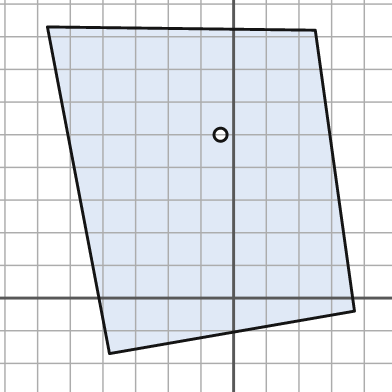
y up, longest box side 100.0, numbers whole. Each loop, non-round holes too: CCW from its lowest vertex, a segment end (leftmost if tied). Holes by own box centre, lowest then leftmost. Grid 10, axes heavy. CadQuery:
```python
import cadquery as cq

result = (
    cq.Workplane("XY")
    .moveTo(-38.0, -17.0)
    .lineTo(37.0, -4.0)
    .lineTo(25.0, 82.0)
    .lineTo(-57.0, 83.0)
    .close()
    .moveTo(-4.0, 50.0)
    .circle(2.0)
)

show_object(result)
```